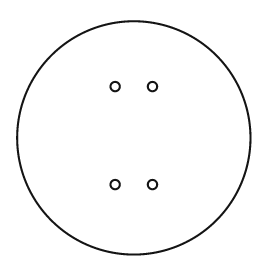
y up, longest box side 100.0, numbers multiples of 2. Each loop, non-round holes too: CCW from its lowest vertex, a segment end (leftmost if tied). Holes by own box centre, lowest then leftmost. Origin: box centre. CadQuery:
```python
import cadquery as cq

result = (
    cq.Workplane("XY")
    .moveTo(0.0, 0.0)
    .circle(50.0)
    .moveTo(-8.0, -20.0)
    .circle(2.0)
    .moveTo(8.0, -20.0)
    .circle(2.0)
    .moveTo(-8.0, 22.0)
    .circle(2.0)
    .moveTo(8.0, 22.0)
    .circle(2.0)
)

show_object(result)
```